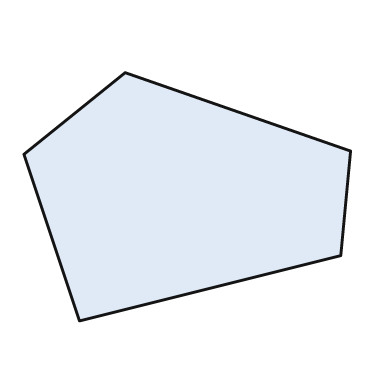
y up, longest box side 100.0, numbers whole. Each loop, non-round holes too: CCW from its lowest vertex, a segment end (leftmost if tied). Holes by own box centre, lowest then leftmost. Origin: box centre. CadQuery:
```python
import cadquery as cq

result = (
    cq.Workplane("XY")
    .moveTo(-33.0, -38.0)
    .lineTo(47.0, -18.0)
    .lineTo(50.0, 14.0)
    .lineTo(-19.0, 38.0)
    .lineTo(-50.0, 13.0)
    .close()
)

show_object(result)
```